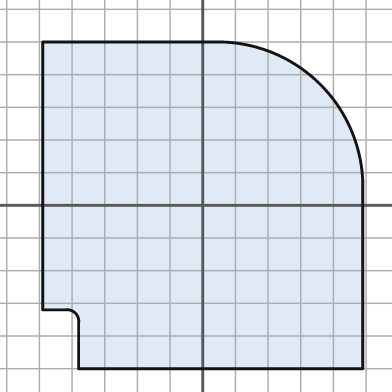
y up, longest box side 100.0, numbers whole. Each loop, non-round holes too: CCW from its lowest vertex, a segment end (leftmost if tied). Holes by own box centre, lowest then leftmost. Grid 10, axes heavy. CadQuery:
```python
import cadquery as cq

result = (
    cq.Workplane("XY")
    .moveTo(-38.0, -50.0)
    .lineTo(49.0, -50.0)
    .lineTo(49.0, 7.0)
    .threePointArc((36.0, 37.0), (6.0, 50.0))
    .lineTo(-49.0, 50.0)
    .lineTo(-49.0, -32.0)
    .lineTo(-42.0, -32.0)
    .threePointArc((-39.0, -33.0), (-38.0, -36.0))
    .close()
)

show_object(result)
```